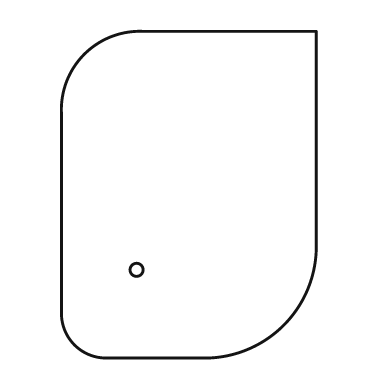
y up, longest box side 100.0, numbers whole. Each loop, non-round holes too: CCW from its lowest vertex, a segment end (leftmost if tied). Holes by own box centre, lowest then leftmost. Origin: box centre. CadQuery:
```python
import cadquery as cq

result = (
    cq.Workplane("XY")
    .moveTo(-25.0, -50.0)
    .lineTo(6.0, -50.0)
    .threePointArc((29.0, -40.0), (39.0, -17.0))
    .lineTo(39.0, 50.0)
    .lineTo(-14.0, 50.0)
    .threePointArc((-32.0, 43.0), (-39.0, 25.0))
    .lineTo(-39.0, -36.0)
    .threePointArc((-35.0, -46.0), (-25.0, -50.0))
    .close()
    .moveTo(-16.0, -23.0)
    .circle(2.0)
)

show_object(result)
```